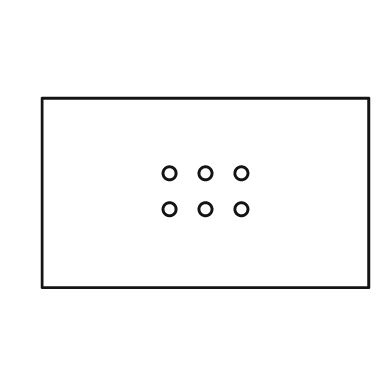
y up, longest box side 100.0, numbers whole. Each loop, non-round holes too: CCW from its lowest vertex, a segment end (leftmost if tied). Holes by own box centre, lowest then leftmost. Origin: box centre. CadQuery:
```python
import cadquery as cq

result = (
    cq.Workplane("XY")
    .moveTo(-50.0, -29.0)
    .lineTo(50.0, -29.0)
    .lineTo(50.0, 29.0)
    .lineTo(-50.0, 29.0)
    .close()
    .moveTo(-11.0, -5.0)
    .circle(2.0)
    .moveTo(0.0, -5.0)
    .circle(2.0)
    .moveTo(11.0, -5.0)
    .circle(2.0)
    .moveTo(-11.0, 6.0)
    .circle(2.0)
    .moveTo(0.0, 6.0)
    .circle(2.0)
    .moveTo(11.0, 6.0)
    .circle(2.0)
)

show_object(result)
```